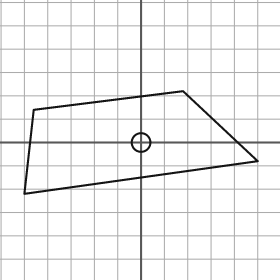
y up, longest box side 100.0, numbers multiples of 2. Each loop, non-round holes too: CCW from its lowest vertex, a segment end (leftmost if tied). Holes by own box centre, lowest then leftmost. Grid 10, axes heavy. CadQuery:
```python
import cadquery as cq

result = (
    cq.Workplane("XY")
    .moveTo(-50.0, -22.0)
    .lineTo(50.0, -8.0)
    .lineTo(18.0, 22.0)
    .lineTo(-46.0, 14.0)
    .close()
    .moveTo(0.0, 0.0)
    .circle(4.0)
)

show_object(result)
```